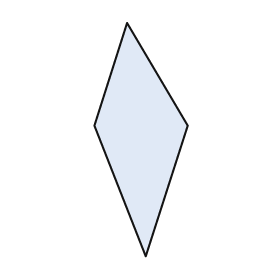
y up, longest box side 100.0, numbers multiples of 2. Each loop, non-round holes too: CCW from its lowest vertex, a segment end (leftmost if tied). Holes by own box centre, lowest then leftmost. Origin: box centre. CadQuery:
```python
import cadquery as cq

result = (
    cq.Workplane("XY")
    .moveTo(2.0, -50.0)
    .lineTo(20.0, 6.0)
    .lineTo(-6.0, 50.0)
    .lineTo(-20.0, 6.0)
    .close()
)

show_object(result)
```